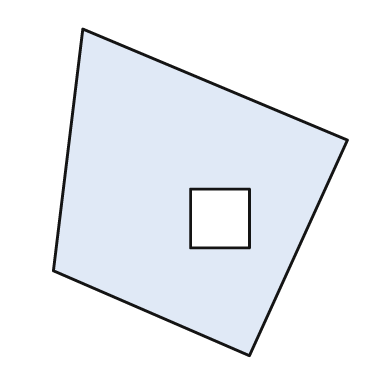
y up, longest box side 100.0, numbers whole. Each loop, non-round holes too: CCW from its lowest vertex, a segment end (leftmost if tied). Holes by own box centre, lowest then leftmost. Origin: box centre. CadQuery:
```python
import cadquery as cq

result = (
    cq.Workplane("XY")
    .moveTo(15.0, -50.0)
    .lineTo(45.0, 16.0)
    .lineTo(-36.0, 50.0)
    .lineTo(-45.0, -24.0)
    .close()
    .moveTo(-3.0, -17.0)
    .lineTo(15.0, -17.0)
    .lineTo(15.0, 1.0)
    .lineTo(-3.0, 1.0)
    .close()
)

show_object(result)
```